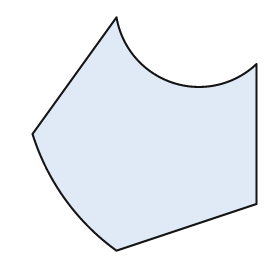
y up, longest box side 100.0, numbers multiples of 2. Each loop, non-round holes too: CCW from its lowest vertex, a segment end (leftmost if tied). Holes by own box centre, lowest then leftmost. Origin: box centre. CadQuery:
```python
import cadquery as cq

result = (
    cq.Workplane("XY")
    .moveTo(-12.0, -50.0)
    .lineTo(48.0, -30.0)
    .lineTo(48.0, 30.0)
    .threePointArc((12.0, 22.0), (-12.0, 50.0))
    .lineTo(-48.0, 0.0)
    .threePointArc((-34.0, -28.0), (-12.0, -50.0))
    .close()
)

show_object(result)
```